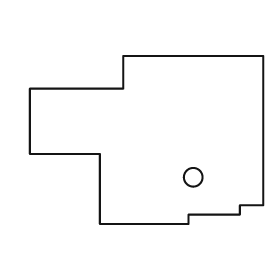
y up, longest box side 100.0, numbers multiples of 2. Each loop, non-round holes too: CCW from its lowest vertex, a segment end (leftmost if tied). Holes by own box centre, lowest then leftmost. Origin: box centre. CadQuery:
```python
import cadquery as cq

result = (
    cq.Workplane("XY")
    .moveTo(-20.0, -36.0)
    .lineTo(18.0, -36.0)
    .lineTo(18.0, -32.0)
    .lineTo(40.0, -32.0)
    .lineTo(40.0, -28.0)
    .lineTo(50.0, -28.0)
    .lineTo(50.0, 36.0)
    .lineTo(-10.0, 36.0)
    .lineTo(-10.0, 22.0)
    .lineTo(-50.0, 22.0)
    .lineTo(-50.0, -6.0)
    .lineTo(-20.0, -6.0)
    .close()
    .moveTo(20.0, -16.0)
    .circle(4.0)
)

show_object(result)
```